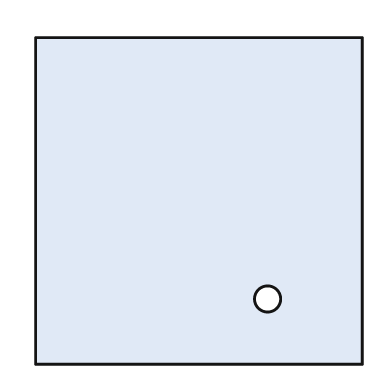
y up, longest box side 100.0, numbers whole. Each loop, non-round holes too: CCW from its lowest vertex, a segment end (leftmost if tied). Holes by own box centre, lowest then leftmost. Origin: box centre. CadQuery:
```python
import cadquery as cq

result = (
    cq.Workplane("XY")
    .moveTo(-50.0, -50.0)
    .lineTo(50.0, -50.0)
    .lineTo(50.0, 50.0)
    .lineTo(-50.0, 50.0)
    .close()
    .moveTo(21.0, -30.0)
    .circle(4.0)
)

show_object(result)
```